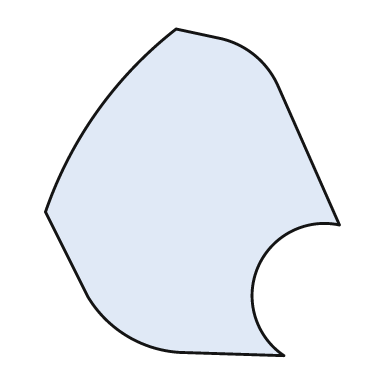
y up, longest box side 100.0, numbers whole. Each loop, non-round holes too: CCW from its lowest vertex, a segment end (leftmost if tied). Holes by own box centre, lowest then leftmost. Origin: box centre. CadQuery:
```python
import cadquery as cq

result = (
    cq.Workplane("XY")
    .moveTo(28.0, -50.0)
    .threePointArc((20.0, -23.0), (45.0, -10.0))
    .lineTo(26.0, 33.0)
    .threePointArc((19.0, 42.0), (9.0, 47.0))
    .lineTo(-5.0, 50.0)
    .threePointArc((-29.0, 25.0), (-45.0, -6.0))
    .lineTo(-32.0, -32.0)
    .threePointArc((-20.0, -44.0), (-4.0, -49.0))
    .close()
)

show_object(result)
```